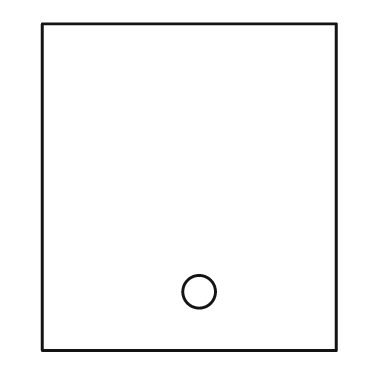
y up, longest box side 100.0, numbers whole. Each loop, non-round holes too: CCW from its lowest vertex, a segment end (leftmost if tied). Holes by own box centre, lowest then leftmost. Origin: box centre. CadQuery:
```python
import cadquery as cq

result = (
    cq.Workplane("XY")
    .moveTo(-45.0, -50.0)
    .lineTo(45.0, -50.0)
    .lineTo(45.0, 50.0)
    .lineTo(-45.0, 50.0)
    .close()
    .moveTo(3.0, -32.0)
    .circle(5.0)
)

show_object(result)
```